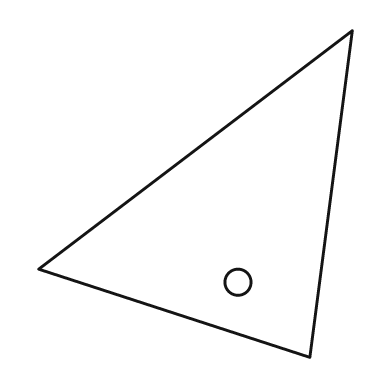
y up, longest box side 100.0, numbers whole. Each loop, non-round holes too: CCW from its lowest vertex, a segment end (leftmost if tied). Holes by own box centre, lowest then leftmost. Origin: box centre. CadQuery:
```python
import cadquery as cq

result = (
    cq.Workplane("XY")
    .moveTo(35.0, -50.0)
    .lineTo(48.0, 50.0)
    .lineTo(-48.0, -23.0)
    .close()
    .moveTo(13.0, -27.0)
    .circle(4.0)
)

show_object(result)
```